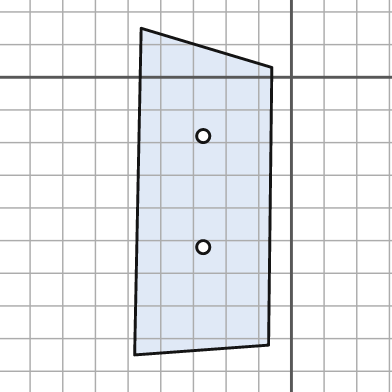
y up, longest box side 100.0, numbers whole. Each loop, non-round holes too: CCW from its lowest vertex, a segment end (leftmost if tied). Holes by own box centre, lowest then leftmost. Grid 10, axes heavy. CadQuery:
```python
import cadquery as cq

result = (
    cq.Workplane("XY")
    .moveTo(-48.0, -85.0)
    .lineTo(-7.0, -82.0)
    .lineTo(-6.0, 3.0)
    .lineTo(-46.0, 15.0)
    .close()
    .moveTo(-27.0, -52.0)
    .circle(2.0)
    .moveTo(-27.0, -18.0)
    .circle(2.0)
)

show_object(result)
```